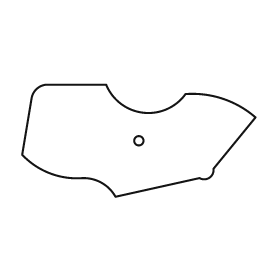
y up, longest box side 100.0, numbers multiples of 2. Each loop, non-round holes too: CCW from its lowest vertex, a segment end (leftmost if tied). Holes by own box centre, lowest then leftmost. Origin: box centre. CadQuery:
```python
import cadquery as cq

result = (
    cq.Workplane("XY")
    .moveTo(-10.0, -24.0)
    .lineTo(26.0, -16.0)
    .threePointArc((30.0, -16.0), (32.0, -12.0))
    .lineTo(50.0, 10.0)
    .threePointArc((36.0, 18.0), (20.0, 20.0))
    .threePointArc((2.0, 12.0), (-14.0, 24.0))
    .lineTo(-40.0, 24.0)
    .threePointArc((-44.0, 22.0), (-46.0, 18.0))
    .lineTo(-50.0, -6.0)
    .threePointArc((-38.0, -14.0), (-24.0, -16.0))
    .threePointArc((-16.0, -18.0), (-10.0, -24.0))
    .close()
    .moveTo(0.0, 0.0)
    .circle(2.0)
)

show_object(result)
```